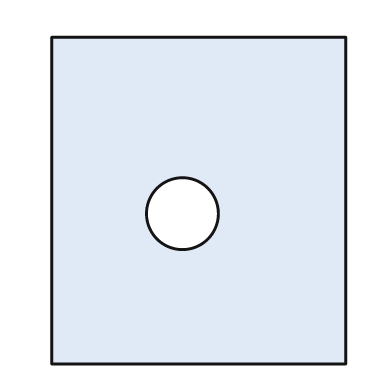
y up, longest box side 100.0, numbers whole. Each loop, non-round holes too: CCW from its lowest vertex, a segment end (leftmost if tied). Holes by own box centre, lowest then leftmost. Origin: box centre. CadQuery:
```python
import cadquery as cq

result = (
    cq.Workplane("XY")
    .moveTo(-45.0, -50.0)
    .lineTo(45.0, -50.0)
    .lineTo(45.0, 50.0)
    .lineTo(-45.0, 50.0)
    .close()
    .moveTo(-5.0, -4.0)
    .circle(11.0)
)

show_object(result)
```